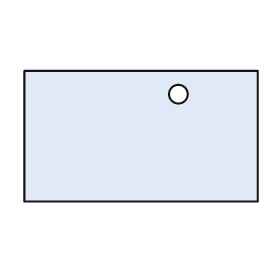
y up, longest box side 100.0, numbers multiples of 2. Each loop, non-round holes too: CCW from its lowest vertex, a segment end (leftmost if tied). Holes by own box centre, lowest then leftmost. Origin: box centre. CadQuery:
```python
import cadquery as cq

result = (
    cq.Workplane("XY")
    .moveTo(-50.0, -28.0)
    .lineTo(50.0, -28.0)
    .lineTo(50.0, 28.0)
    .lineTo(-50.0, 28.0)
    .close()
    .moveTo(16.0, 18.0)
    .circle(4.0)
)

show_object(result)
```